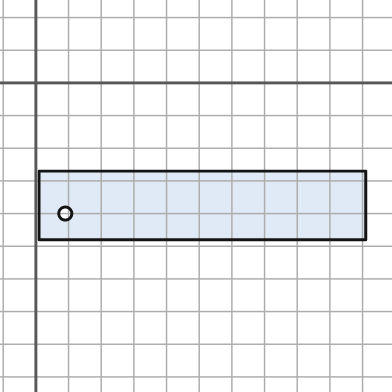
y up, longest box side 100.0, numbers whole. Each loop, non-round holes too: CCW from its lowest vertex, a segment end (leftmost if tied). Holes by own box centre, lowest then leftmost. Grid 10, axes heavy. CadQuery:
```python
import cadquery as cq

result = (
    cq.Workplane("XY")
    .moveTo(1.0, -48.0)
    .lineTo(101.0, -48.0)
    .lineTo(101.0, -27.0)
    .lineTo(1.0, -27.0)
    .close()
    .moveTo(9.0, -40.0)
    .circle(2.0)
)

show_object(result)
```